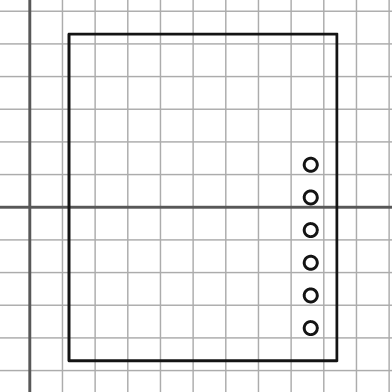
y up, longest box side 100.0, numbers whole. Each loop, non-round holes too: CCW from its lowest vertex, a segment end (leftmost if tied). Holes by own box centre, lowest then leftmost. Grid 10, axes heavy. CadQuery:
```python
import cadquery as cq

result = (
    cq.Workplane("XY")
    .moveTo(12.0, -47.0)
    .lineTo(94.0, -47.0)
    .lineTo(94.0, 53.0)
    .lineTo(12.0, 53.0)
    .close()
    .moveTo(86.0, -37.0)
    .circle(2.0)
    .moveTo(86.0, -27.0)
    .circle(2.0)
    .moveTo(86.0, -17.0)
    .circle(2.0)
    .moveTo(86.0, -7.0)
    .circle(2.0)
    .moveTo(86.0, 3.0)
    .circle(2.0)
    .moveTo(86.0, 13.0)
    .circle(2.0)
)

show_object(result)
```